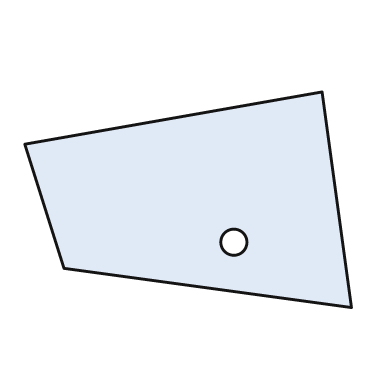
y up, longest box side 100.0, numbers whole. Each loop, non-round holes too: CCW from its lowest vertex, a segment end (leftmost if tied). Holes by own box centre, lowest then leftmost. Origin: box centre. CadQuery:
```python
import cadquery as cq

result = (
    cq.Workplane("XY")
    .moveTo(50.0, -33.0)
    .lineTo(41.0, 33.0)
    .lineTo(-50.0, 17.0)
    .lineTo(-38.0, -21.0)
    .close()
    .moveTo(14.0, -13.0)
    .circle(4.0)
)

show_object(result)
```